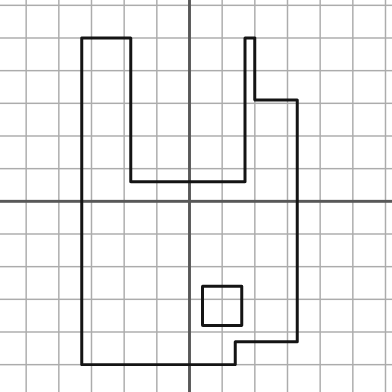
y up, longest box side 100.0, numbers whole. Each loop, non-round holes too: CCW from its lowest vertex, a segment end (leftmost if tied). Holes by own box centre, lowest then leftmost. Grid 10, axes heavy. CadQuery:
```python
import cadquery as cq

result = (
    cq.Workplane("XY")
    .moveTo(-33.0, -50.0)
    .lineTo(14.0, -50.0)
    .lineTo(14.0, -43.0)
    .lineTo(33.0, -43.0)
    .lineTo(33.0, 31.0)
    .lineTo(20.0, 31.0)
    .lineTo(20.0, 50.0)
    .lineTo(17.0, 50.0)
    .lineTo(17.0, 6.0)
    .lineTo(-18.0, 6.0)
    .lineTo(-18.0, 50.0)
    .lineTo(-33.0, 50.0)
    .close()
    .moveTo(4.0, -38.0)
    .lineTo(16.0, -38.0)
    .lineTo(16.0, -26.0)
    .lineTo(4.0, -26.0)
    .close()
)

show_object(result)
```